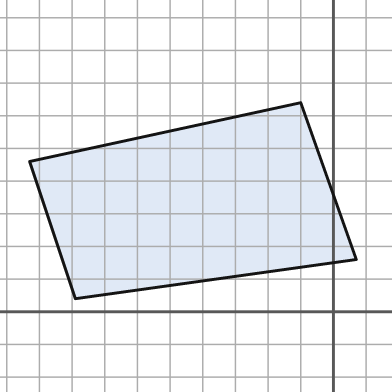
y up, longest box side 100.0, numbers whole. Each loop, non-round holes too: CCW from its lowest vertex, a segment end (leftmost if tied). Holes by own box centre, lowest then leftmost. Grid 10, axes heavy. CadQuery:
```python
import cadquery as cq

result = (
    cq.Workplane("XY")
    .moveTo(-79.0, 4.0)
    .lineTo(7.0, 16.0)
    .lineTo(-10.0, 64.0)
    .lineTo(-93.0, 46.0)
    .close()
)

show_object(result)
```